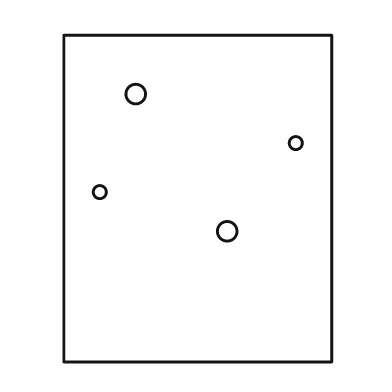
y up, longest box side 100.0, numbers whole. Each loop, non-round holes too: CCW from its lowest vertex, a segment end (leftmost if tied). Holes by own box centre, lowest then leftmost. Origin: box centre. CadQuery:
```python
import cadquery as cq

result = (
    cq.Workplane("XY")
    .moveTo(-41.0, -50.0)
    .lineTo(41.0, -50.0)
    .lineTo(41.0, 50.0)
    .lineTo(-41.0, 50.0)
    .close()
    .moveTo(9.0, -10.0)
    .circle(3.0)
    .moveTo(-30.0, 2.0)
    .circle(2.0)
    .moveTo(30.0, 17.0)
    .circle(2.0)
    .moveTo(-19.0, 32.0)
    .circle(3.0)
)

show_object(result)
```